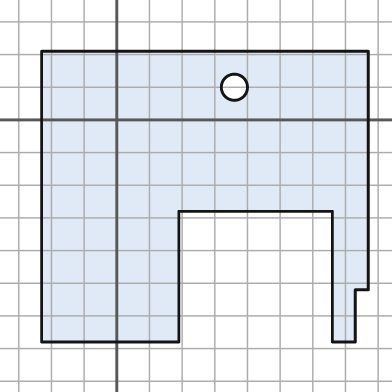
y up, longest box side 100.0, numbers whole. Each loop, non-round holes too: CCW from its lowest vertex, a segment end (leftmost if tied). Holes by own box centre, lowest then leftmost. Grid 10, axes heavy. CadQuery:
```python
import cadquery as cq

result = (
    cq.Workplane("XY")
    .moveTo(-23.0, -68.0)
    .lineTo(19.0, -68.0)
    .lineTo(19.0, -28.0)
    .lineTo(66.0, -28.0)
    .lineTo(66.0, -68.0)
    .lineTo(73.0, -68.0)
    .lineTo(73.0, -52.0)
    .lineTo(77.0, -52.0)
    .lineTo(77.0, 21.0)
    .lineTo(-23.0, 21.0)
    .close()
    .moveTo(36.0, 10.0)
    .circle(4.0)
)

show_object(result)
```